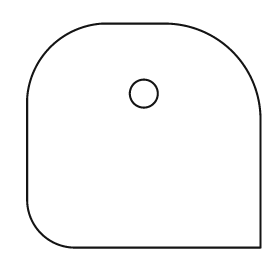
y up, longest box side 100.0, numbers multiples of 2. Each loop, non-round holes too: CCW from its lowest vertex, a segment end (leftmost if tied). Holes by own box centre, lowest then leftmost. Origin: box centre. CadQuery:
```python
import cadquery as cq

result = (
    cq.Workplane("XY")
    .moveTo(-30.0, -48.0)
    .lineTo(50.0, -48.0)
    .lineTo(50.0, 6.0)
    .threePointArc((38.0, 36.0), (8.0, 48.0))
    .lineTo(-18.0, 48.0)
    .threePointArc((-40.0, 38.0), (-50.0, 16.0))
    .lineTo(-50.0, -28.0)
    .threePointArc((-44.0, -42.0), (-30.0, -48.0))
    .close()
    .moveTo(0.0, 18.0)
    .circle(6.0)
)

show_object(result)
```